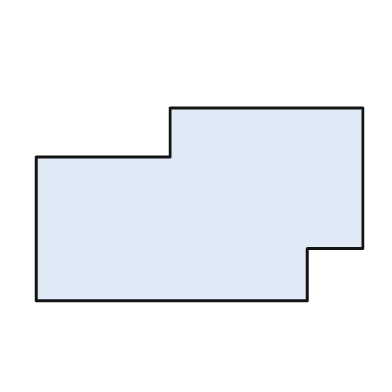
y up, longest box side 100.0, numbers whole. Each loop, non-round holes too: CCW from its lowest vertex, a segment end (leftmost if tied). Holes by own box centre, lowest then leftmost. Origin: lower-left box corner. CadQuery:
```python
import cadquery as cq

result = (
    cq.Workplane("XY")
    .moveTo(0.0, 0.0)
    .lineTo(83.0, 0.0)
    .lineTo(83.0, 16.0)
    .lineTo(100.0, 16.0)
    .lineTo(100.0, 59.0)
    .lineTo(41.0, 59.0)
    .lineTo(41.0, 44.0)
    .lineTo(0.0, 44.0)
    .close()
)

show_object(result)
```